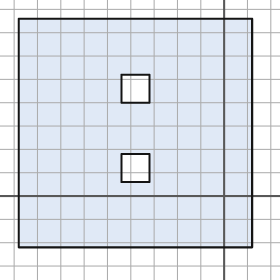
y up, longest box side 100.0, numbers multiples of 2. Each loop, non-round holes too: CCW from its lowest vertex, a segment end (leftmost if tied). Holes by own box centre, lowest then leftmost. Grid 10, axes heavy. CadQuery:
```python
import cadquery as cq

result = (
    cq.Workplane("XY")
    .moveTo(-88.0, -22.0)
    .lineTo(12.0, -22.0)
    .lineTo(12.0, 76.0)
    .lineTo(-88.0, 76.0)
    .close()
    .moveTo(-44.0, 6.0)
    .lineTo(-32.0, 6.0)
    .lineTo(-32.0, 18.0)
    .lineTo(-44.0, 18.0)
    .close()
    .moveTo(-44.0, 40.0)
    .lineTo(-32.0, 40.0)
    .lineTo(-32.0, 52.0)
    .lineTo(-44.0, 52.0)
    .close()
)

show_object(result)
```